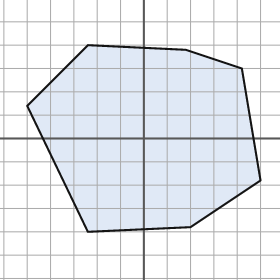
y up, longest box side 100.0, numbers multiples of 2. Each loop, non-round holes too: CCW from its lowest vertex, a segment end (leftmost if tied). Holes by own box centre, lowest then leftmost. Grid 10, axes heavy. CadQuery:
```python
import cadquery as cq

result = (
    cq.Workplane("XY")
    .moveTo(-24.0, -40.0)
    .lineTo(20.0, -38.0)
    .lineTo(50.0, -18.0)
    .lineTo(42.0, 30.0)
    .lineTo(18.0, 38.0)
    .lineTo(-24.0, 40.0)
    .lineTo(-50.0, 14.0)
    .close()
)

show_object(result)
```